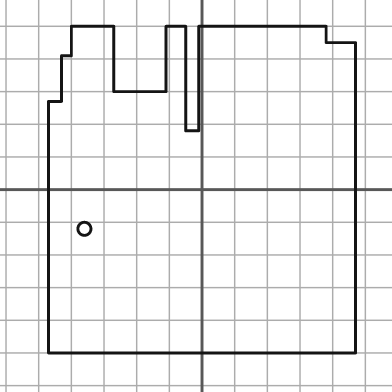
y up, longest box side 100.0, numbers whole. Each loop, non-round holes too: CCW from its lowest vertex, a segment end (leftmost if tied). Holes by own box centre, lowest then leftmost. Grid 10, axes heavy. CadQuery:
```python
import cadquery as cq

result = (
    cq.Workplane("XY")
    .moveTo(-47.0, -50.0)
    .lineTo(47.0, -50.0)
    .lineTo(47.0, 45.0)
    .lineTo(38.0, 45.0)
    .lineTo(38.0, 50.0)
    .lineTo(-1.0, 50.0)
    .lineTo(-1.0, 18.0)
    .lineTo(-5.0, 18.0)
    .lineTo(-5.0, 50.0)
    .lineTo(-11.0, 50.0)
    .lineTo(-11.0, 30.0)
    .lineTo(-27.0, 30.0)
    .lineTo(-27.0, 50.0)
    .lineTo(-40.0, 50.0)
    .lineTo(-40.0, 41.0)
    .lineTo(-43.0, 41.0)
    .lineTo(-43.0, 27.0)
    .lineTo(-47.0, 27.0)
    .close()
    .moveTo(-36.0, -12.0)
    .circle(2.0)
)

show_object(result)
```